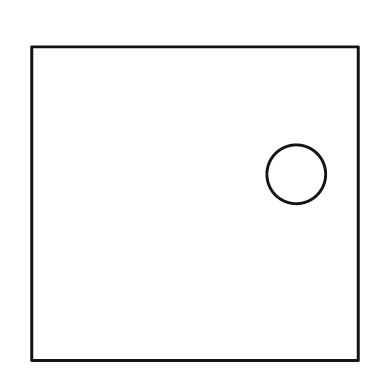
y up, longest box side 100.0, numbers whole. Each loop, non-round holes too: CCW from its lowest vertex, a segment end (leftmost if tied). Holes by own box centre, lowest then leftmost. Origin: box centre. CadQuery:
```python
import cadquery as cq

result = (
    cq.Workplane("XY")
    .moveTo(-50.0, -48.0)
    .lineTo(50.0, -48.0)
    .lineTo(50.0, 48.0)
    .lineTo(-50.0, 48.0)
    .close()
    .moveTo(31.0, 9.0)
    .circle(9.0)
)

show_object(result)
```